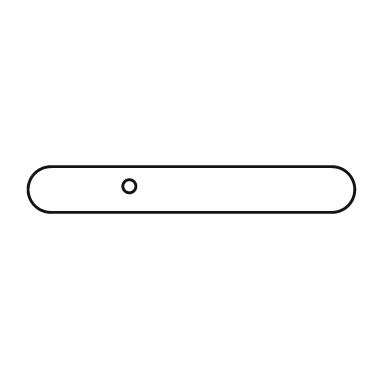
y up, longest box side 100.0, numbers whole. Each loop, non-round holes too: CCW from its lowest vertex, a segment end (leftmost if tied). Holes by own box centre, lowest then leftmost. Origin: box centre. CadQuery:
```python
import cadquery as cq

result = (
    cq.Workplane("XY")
    .moveTo(-43.0, -7.0)
    .lineTo(43.0, -7.0)
    .threePointArc((50.0, 0.0), (43.0, 7.0))
    .lineTo(-43.0, 7.0)
    .threePointArc((-50.0, 0.0), (-43.0, -7.0))
    .close()
    .moveTo(-19.0, 1.0)
    .circle(2.0)
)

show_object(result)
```